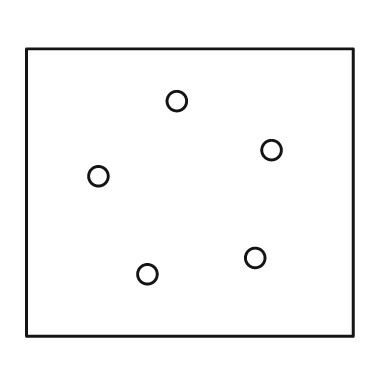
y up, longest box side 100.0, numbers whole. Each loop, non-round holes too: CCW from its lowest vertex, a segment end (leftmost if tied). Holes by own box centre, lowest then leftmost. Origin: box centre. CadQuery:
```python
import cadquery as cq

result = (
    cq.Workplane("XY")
    .moveTo(-50.0, -44.0)
    .lineTo(50.0, -44.0)
    .lineTo(50.0, 44.0)
    .lineTo(-50.0, 44.0)
    .close()
    .moveTo(-13.0, -25.0)
    .circle(3.0)
    .moveTo(20.0, -20.0)
    .circle(3.0)
    .moveTo(-28.0, 5.0)
    .circle(3.0)
    .moveTo(25.0, 13.0)
    .circle(3.0)
    .moveTo(-4.0, 28.0)
    .circle(3.0)
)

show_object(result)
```